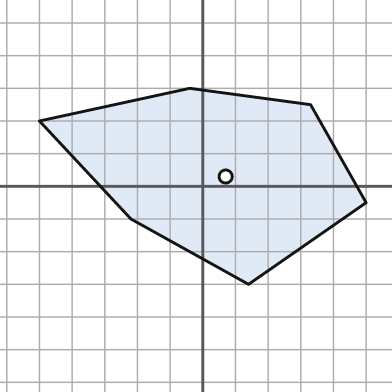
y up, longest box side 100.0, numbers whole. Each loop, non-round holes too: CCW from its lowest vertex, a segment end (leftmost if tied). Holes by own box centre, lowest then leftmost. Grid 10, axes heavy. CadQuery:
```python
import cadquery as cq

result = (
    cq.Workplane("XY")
    .moveTo(14.0, -30.0)
    .lineTo(50.0, -5.0)
    .lineTo(33.0, 25.0)
    .lineTo(-4.0, 30.0)
    .lineTo(-50.0, 20.0)
    .lineTo(-22.0, -10.0)
    .close()
    .moveTo(7.0, 3.0)
    .circle(2.0)
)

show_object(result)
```